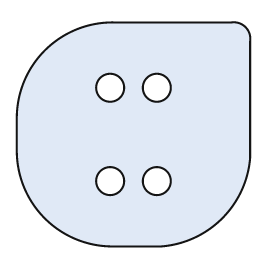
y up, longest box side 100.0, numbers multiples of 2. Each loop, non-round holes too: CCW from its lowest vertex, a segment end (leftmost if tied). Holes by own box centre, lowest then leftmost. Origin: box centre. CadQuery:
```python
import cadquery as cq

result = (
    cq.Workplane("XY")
    .moveTo(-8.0, -48.0)
    .lineTo(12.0, -48.0)
    .threePointArc((38.0, -36.0), (50.0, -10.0))
    .lineTo(50.0, 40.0)
    .threePointArc((48.0, 46.0), (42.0, 48.0))
    .lineTo(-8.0, 48.0)
    .threePointArc((-38.0, 36.0), (-50.0, 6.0))
    .lineTo(-50.0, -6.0)
    .threePointArc((-38.0, -36.0), (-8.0, -48.0))
    .close()
    .moveTo(-10.0, -20.0)
    .circle(6.0)
    .moveTo(10.0, -20.0)
    .circle(6.0)
    .moveTo(-10.0, 20.0)
    .circle(6.0)
    .moveTo(10.0, 20.0)
    .circle(6.0)
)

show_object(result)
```